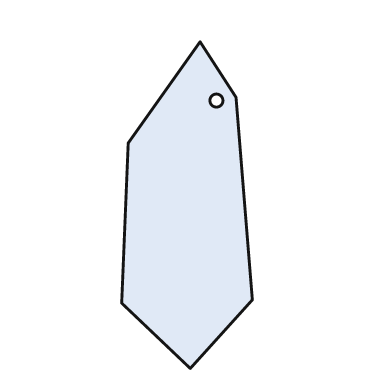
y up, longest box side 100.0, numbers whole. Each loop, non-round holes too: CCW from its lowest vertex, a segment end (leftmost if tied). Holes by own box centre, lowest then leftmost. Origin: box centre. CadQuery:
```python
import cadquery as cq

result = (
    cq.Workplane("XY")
    .moveTo(1.0, -50.0)
    .lineTo(20.0, -29.0)
    .lineTo(15.0, 33.0)
    .lineTo(4.0, 50.0)
    .lineTo(-18.0, 19.0)
    .lineTo(-20.0, -30.0)
    .close()
    .moveTo(9.0, 32.0)
    .circle(2.0)
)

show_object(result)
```